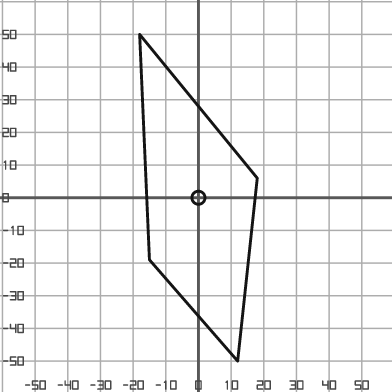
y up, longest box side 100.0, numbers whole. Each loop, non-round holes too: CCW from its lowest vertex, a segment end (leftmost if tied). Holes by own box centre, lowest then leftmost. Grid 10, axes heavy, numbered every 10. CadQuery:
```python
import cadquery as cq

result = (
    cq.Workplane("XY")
    .moveTo(12.0, -50.0)
    .lineTo(18.0, 6.0)
    .lineTo(-18.0, 50.0)
    .lineTo(-15.0, -19.0)
    .close()
    .moveTo(0.0, 0.0)
    .circle(2.0)
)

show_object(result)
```